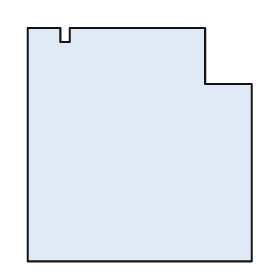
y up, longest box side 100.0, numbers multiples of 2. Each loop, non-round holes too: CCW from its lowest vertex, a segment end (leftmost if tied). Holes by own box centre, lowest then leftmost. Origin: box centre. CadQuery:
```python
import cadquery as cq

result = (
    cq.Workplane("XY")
    .moveTo(-48.0, -50.0)
    .lineTo(48.0, -50.0)
    .lineTo(48.0, 26.0)
    .lineTo(28.0, 26.0)
    .lineTo(28.0, 50.0)
    .lineTo(-30.0, 50.0)
    .lineTo(-30.0, 44.0)
    .lineTo(-34.0, 44.0)
    .lineTo(-34.0, 50.0)
    .lineTo(-48.0, 50.0)
    .close()
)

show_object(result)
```